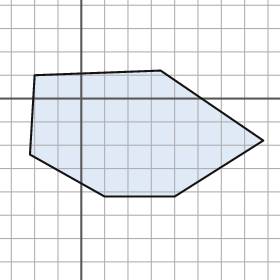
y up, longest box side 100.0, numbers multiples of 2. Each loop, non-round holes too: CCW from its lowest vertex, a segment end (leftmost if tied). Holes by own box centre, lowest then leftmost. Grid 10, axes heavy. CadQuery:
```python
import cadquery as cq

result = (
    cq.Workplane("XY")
    .moveTo(10.0, -42.0)
    .lineTo(40.0, -42.0)
    .lineTo(78.0, -18.0)
    .lineTo(34.0, 12.0)
    .lineTo(-20.0, 10.0)
    .lineTo(-22.0, -24.0)
    .close()
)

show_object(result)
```